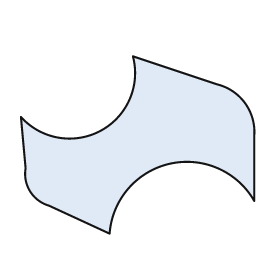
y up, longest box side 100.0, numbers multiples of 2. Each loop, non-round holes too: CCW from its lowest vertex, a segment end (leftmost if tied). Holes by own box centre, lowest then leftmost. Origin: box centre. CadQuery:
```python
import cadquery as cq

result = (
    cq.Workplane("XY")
    .moveTo(-12.0, -38.0)
    .threePointArc((14.0, -8.0), (50.0, -24.0))
    .lineTo(50.0, 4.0)
    .threePointArc((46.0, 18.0), (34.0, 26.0))
    .lineTo(-2.0, 38.0)
    .threePointArc((-16.0, 6.0), (-50.0, 12.0))
    .lineTo(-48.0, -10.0)
    .threePointArc((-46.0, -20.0), (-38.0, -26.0))
    .close()
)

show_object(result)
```